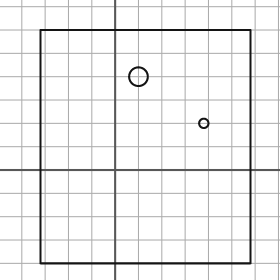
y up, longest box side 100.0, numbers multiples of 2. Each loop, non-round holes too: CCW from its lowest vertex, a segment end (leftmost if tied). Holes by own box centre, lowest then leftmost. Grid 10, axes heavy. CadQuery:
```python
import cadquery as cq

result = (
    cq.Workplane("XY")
    .moveTo(-32.0, -40.0)
    .lineTo(58.0, -40.0)
    .lineTo(58.0, 60.0)
    .lineTo(-32.0, 60.0)
    .close()
    .moveTo(38.0, 20.0)
    .circle(2.0)
    .moveTo(10.0, 40.0)
    .circle(4.0)
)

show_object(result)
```